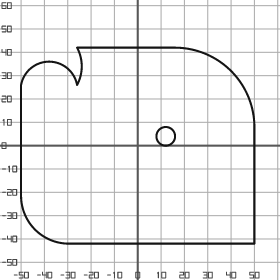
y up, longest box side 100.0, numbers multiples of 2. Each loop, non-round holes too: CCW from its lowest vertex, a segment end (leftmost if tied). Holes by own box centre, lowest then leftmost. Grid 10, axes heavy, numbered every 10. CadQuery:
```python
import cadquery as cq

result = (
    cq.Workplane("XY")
    .moveTo(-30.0, -42.0)
    .lineTo(50.0, -42.0)
    .lineTo(50.0, 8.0)
    .threePointArc((40.0, 32.0), (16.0, 42.0))
    .lineTo(-26.0, 42.0)
    .threePointArc((-24.0, 34.0), (-26.0, 26.0))
    .threePointArc((-38.0, 36.0), (-50.0, 26.0))
    .lineTo(-50.0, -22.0)
    .threePointArc((-44.0, -36.0), (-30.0, -42.0))
    .close()
    .moveTo(12.0, 4.0)
    .circle(4.0)
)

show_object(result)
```